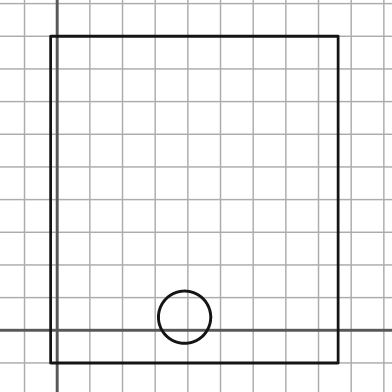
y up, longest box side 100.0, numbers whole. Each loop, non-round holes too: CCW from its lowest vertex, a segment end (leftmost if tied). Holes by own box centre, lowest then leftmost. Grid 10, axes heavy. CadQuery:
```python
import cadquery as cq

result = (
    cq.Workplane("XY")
    .moveTo(-2.0, -10.0)
    .lineTo(86.0, -10.0)
    .lineTo(86.0, 90.0)
    .lineTo(-2.0, 90.0)
    .close()
    .moveTo(39.0, 4.0)
    .circle(8.0)
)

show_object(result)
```